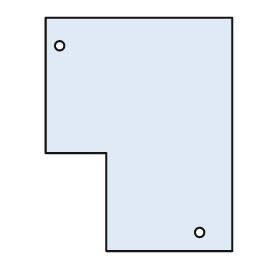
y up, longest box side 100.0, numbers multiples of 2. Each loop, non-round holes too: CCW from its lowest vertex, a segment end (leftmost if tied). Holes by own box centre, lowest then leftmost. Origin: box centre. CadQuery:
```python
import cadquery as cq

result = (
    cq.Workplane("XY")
    .moveTo(-14.0, -50.0)
    .lineTo(40.0, -50.0)
    .lineTo(40.0, 50.0)
    .lineTo(-40.0, 50.0)
    .lineTo(-40.0, -8.0)
    .lineTo(-14.0, -8.0)
    .close()
    .moveTo(26.0, -42.0)
    .circle(2.0)
    .moveTo(-34.0, 38.0)
    .circle(2.0)
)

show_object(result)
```